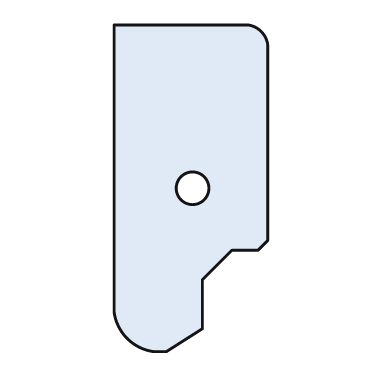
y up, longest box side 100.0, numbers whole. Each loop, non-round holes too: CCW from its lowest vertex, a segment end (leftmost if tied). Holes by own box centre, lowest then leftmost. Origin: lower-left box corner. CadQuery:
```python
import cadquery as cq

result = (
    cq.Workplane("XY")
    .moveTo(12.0, 0.0)
    .lineTo(16.0, 0.0)
    .lineTo(27.0, 7.0)
    .lineTo(27.0, 22.0)
    .lineTo(36.0, 31.0)
    .lineTo(44.0, 31.0)
    .lineTo(47.0, 34.0)
    .lineTo(47.0, 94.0)
    .threePointArc((45.0, 98.0), (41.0, 100.0))
    .lineTo(0.0, 100.0)
    .lineTo(0.0, 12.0)
    .threePointArc((4.0, 4.0), (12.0, 0.0))
    .close()
    .moveTo(24.0, 50.0)
    .circle(5.0)
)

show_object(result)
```